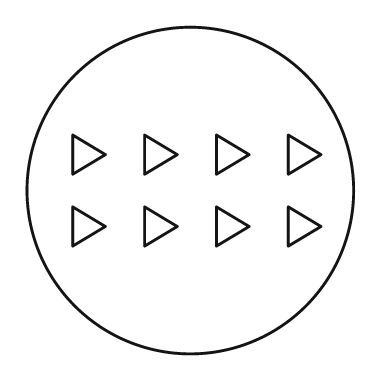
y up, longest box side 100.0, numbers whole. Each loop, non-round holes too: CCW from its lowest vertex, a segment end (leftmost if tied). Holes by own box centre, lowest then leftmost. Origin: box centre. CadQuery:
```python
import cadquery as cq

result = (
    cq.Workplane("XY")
    .moveTo(0.0, 0.0)
    .circle(50.0)
    .moveTo(-36.0, -17.0)
    .lineTo(-26.0, -11.0)
    .lineTo(-36.0, -5.0)
    .close()
    .moveTo(-14.0, -17.0)
    .lineTo(-4.0, -11.0)
    .lineTo(-14.0, -5.0)
    .close()
    .moveTo(8.0, -17.0)
    .lineTo(18.0, -11.0)
    .lineTo(8.0, -5.0)
    .close()
    .moveTo(30.0, -17.0)
    .lineTo(40.0, -11.0)
    .lineTo(30.0, -5.0)
    .close()
    .moveTo(-36.0, 5.0)
    .lineTo(-26.0, 11.0)
    .lineTo(-36.0, 17.0)
    .close()
    .moveTo(-14.0, 5.0)
    .lineTo(-4.0, 11.0)
    .lineTo(-14.0, 17.0)
    .close()
    .moveTo(8.0, 5.0)
    .lineTo(18.0, 11.0)
    .lineTo(8.0, 17.0)
    .close()
    .moveTo(30.0, 5.0)
    .lineTo(40.0, 11.0)
    .lineTo(30.0, 17.0)
    .close()
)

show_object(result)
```